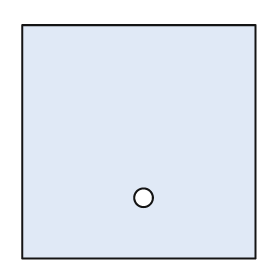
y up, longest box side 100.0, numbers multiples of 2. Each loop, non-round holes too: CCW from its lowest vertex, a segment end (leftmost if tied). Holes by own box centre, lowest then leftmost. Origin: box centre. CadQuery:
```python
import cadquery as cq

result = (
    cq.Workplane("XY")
    .moveTo(-50.0, -50.0)
    .lineTo(50.0, -50.0)
    .lineTo(50.0, 50.0)
    .lineTo(-50.0, 50.0)
    .close()
    .moveTo(2.0, -24.0)
    .circle(4.0)
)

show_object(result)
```